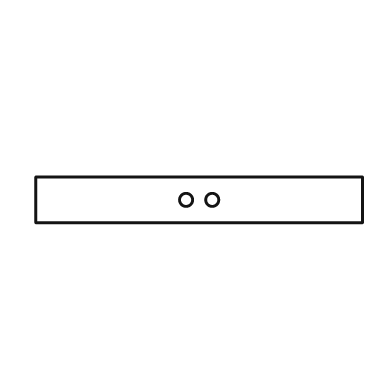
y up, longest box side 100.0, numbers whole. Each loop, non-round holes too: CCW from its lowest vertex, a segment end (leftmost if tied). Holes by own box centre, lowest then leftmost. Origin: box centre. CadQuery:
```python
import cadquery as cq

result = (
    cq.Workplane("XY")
    .moveTo(-50.0, -7.0)
    .lineTo(50.0, -7.0)
    .lineTo(50.0, 7.0)
    .lineTo(-50.0, 7.0)
    .close()
    .moveTo(-4.0, 0.0)
    .circle(2.0)
    .moveTo(4.0, 0.0)
    .circle(2.0)
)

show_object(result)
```